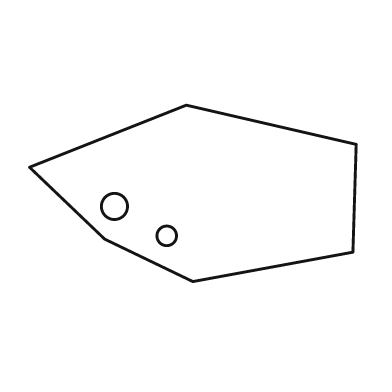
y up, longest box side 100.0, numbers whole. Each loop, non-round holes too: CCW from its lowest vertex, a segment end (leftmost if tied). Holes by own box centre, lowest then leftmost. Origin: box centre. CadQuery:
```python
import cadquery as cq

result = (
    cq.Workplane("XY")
    .moveTo(0.0, -27.0)
    .lineTo(49.0, -18.0)
    .lineTo(50.0, 15.0)
    .lineTo(-2.0, 27.0)
    .lineTo(-50.0, 8.0)
    .lineTo(-27.0, -14.0)
    .close()
    .moveTo(-8.0, -13.0)
    .circle(3.0)
    .moveTo(-24.0, -4.0)
    .circle(4.0)
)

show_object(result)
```